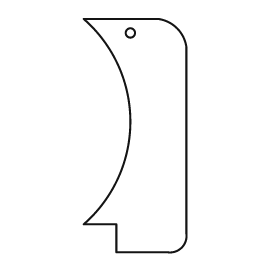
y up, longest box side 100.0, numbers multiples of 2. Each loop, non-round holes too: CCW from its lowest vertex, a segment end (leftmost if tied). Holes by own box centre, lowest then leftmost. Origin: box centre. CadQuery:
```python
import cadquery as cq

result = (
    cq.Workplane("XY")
    .moveTo(-8.0, -50.0)
    .lineTo(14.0, -50.0)
    .threePointArc((20.0, -48.0), (22.0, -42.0))
    .lineTo(22.0, 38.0)
    .threePointArc((18.0, 46.0), (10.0, 50.0))
    .lineTo(-22.0, 50.0)
    .threePointArc((-2.0, 6.0), (-22.0, -38.0))
    .lineTo(-8.0, -38.0)
    .close()
    .moveTo(-2.0, 44.0)
    .circle(2.0)
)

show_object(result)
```